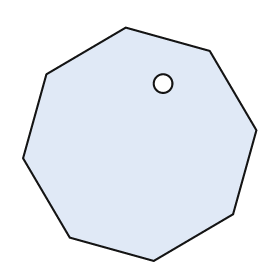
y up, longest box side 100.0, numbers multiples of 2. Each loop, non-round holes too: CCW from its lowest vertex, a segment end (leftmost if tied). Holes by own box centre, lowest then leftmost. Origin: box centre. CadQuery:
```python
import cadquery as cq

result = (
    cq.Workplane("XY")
    .moveTo(6.0, -50.0)
    .lineTo(40.0, -30.0)
    .lineTo(50.0, 6.0)
    .lineTo(30.0, 40.0)
    .lineTo(-6.0, 50.0)
    .lineTo(-40.0, 30.0)
    .lineTo(-50.0, -6.0)
    .lineTo(-30.0, -40.0)
    .close()
    .moveTo(10.0, 26.0)
    .circle(4.0)
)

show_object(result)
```